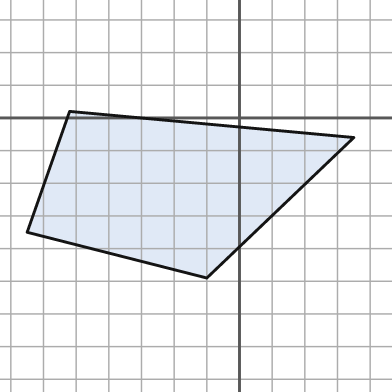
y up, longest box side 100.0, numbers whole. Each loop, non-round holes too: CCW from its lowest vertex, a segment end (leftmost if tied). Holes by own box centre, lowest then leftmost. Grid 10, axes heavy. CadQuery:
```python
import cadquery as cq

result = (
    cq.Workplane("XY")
    .moveTo(-10.0, -49.0)
    .lineTo(35.0, -6.0)
    .lineTo(-52.0, 2.0)
    .lineTo(-65.0, -35.0)
    .close()
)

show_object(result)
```